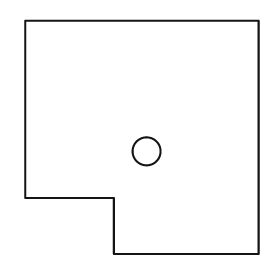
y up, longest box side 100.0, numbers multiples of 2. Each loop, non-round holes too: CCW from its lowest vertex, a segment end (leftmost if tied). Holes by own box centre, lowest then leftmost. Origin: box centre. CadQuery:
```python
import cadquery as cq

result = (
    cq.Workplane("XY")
    .moveTo(-12.0, -50.0)
    .lineTo(50.0, -50.0)
    .lineTo(50.0, 50.0)
    .lineTo(-50.0, 50.0)
    .lineTo(-50.0, -26.0)
    .lineTo(-12.0, -26.0)
    .close()
    .moveTo(2.0, -6.0)
    .circle(6.0)
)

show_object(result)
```